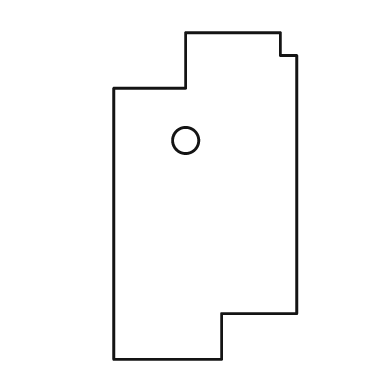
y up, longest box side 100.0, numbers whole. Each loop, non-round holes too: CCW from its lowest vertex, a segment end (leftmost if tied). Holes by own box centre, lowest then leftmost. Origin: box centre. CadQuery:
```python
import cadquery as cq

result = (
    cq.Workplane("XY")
    .moveTo(-28.0, -50.0)
    .lineTo(5.0, -50.0)
    .lineTo(5.0, -36.0)
    .lineTo(28.0, -36.0)
    .lineTo(28.0, 43.0)
    .lineTo(23.0, 43.0)
    .lineTo(23.0, 50.0)
    .lineTo(-6.0, 50.0)
    .lineTo(-6.0, 33.0)
    .lineTo(-28.0, 33.0)
    .close()
    .moveTo(-6.0, 17.0)
    .circle(4.0)
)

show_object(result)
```